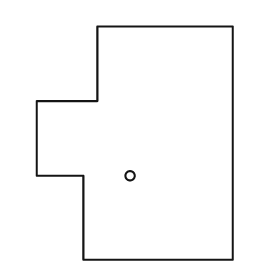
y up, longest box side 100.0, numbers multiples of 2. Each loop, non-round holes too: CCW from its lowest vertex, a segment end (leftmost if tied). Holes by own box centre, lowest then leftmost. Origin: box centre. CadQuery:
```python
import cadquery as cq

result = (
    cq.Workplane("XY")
    .moveTo(-22.0, -50.0)
    .lineTo(42.0, -50.0)
    .lineTo(42.0, 50.0)
    .lineTo(-16.0, 50.0)
    .lineTo(-16.0, 18.0)
    .lineTo(-42.0, 18.0)
    .lineTo(-42.0, -14.0)
    .lineTo(-22.0, -14.0)
    .close()
    .moveTo(-2.0, -14.0)
    .circle(2.0)
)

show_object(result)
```